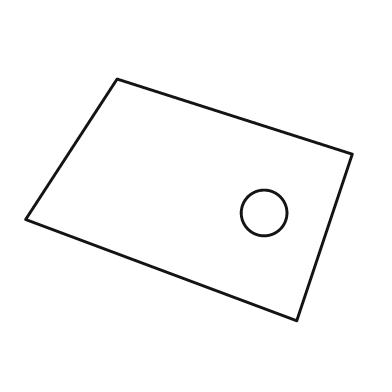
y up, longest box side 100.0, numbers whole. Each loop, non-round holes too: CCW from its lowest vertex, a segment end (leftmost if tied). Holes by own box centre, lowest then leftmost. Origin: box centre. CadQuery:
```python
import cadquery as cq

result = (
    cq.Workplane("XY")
    .moveTo(33.0, -37.0)
    .lineTo(50.0, 14.0)
    .lineTo(-22.0, 37.0)
    .lineTo(-50.0, -6.0)
    .close()
    .moveTo(23.0, -4.0)
    .circle(7.0)
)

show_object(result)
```